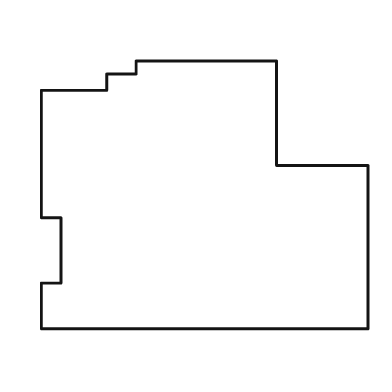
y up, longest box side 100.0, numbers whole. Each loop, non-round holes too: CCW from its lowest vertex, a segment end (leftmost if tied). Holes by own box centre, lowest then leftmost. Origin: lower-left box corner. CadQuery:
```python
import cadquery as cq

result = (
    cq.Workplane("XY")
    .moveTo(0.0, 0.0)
    .lineTo(100.0, 0.0)
    .lineTo(100.0, 50.0)
    .lineTo(72.0, 50.0)
    .lineTo(72.0, 82.0)
    .lineTo(29.0, 82.0)
    .lineTo(29.0, 78.0)
    .lineTo(20.0, 78.0)
    .lineTo(20.0, 73.0)
    .lineTo(0.0, 73.0)
    .lineTo(0.0, 34.0)
    .lineTo(6.0, 34.0)
    .lineTo(6.0, 14.0)
    .lineTo(0.0, 14.0)
    .close()
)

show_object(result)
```